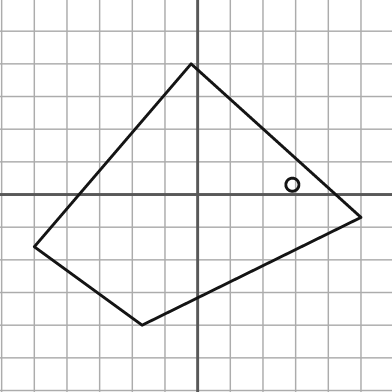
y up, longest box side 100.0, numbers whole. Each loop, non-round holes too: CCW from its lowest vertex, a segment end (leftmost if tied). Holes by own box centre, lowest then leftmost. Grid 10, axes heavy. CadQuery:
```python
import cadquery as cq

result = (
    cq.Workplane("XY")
    .moveTo(-17.0, -40.0)
    .lineTo(50.0, -7.0)
    .lineTo(-2.0, 40.0)
    .lineTo(-50.0, -16.0)
    .close()
    .moveTo(29.0, 3.0)
    .circle(2.0)
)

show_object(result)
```